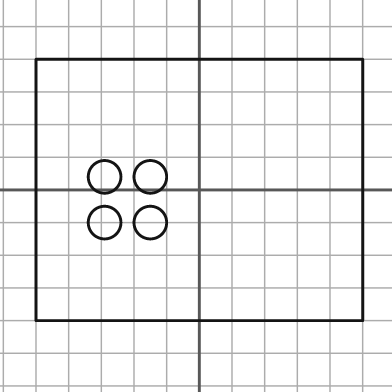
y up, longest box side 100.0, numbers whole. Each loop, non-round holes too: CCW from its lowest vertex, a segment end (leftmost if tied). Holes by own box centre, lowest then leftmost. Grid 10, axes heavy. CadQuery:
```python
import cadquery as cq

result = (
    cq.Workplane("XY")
    .moveTo(-50.0, -40.0)
    .lineTo(50.0, -40.0)
    .lineTo(50.0, 40.0)
    .lineTo(-50.0, 40.0)
    .close()
    .moveTo(-29.0, -10.0)
    .circle(5.0)
    .moveTo(-15.0, -10.0)
    .circle(5.0)
    .moveTo(-29.0, 4.0)
    .circle(5.0)
    .moveTo(-15.0, 4.0)
    .circle(5.0)
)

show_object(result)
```